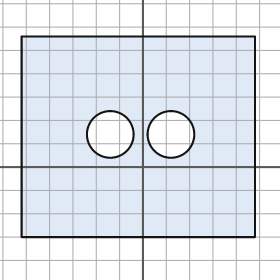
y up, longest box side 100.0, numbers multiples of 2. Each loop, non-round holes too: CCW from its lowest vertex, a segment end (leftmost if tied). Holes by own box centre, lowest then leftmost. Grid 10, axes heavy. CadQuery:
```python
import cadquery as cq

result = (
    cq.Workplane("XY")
    .moveTo(-52.0, -30.0)
    .lineTo(48.0, -30.0)
    .lineTo(48.0, 56.0)
    .lineTo(-52.0, 56.0)
    .close()
    .moveTo(-14.0, 14.0)
    .circle(10.0)
    .moveTo(12.0, 14.0)
    .circle(10.0)
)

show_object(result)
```